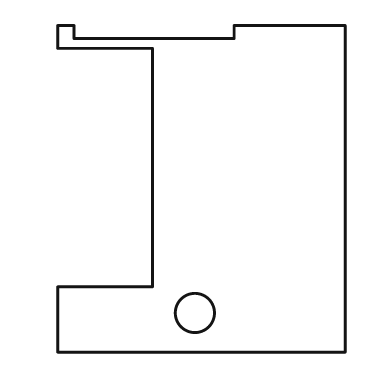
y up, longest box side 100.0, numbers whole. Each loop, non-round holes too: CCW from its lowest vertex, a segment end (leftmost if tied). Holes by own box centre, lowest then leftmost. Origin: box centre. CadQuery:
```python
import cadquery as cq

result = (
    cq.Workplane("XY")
    .moveTo(-44.0, -50.0)
    .lineTo(44.0, -50.0)
    .lineTo(44.0, 50.0)
    .lineTo(10.0, 50.0)
    .lineTo(10.0, 46.0)
    .lineTo(-39.0, 46.0)
    .lineTo(-39.0, 50.0)
    .lineTo(-44.0, 50.0)
    .lineTo(-44.0, 43.0)
    .lineTo(-15.0, 43.0)
    .lineTo(-15.0, -30.0)
    .lineTo(-44.0, -30.0)
    .close()
    .moveTo(-2.0, -38.0)
    .circle(6.0)
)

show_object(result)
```